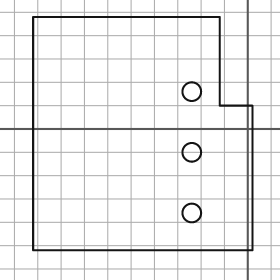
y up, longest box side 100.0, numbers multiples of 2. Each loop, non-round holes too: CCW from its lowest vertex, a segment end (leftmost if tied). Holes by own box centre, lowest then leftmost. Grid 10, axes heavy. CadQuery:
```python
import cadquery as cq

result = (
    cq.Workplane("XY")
    .moveTo(-92.0, -52.0)
    .lineTo(2.0, -52.0)
    .lineTo(2.0, 10.0)
    .lineTo(-12.0, 10.0)
    .lineTo(-12.0, 48.0)
    .lineTo(-92.0, 48.0)
    .close()
    .moveTo(-24.0, -36.0)
    .circle(4.0)
    .moveTo(-24.0, -10.0)
    .circle(4.0)
    .moveTo(-24.0, 16.0)
    .circle(4.0)
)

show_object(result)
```